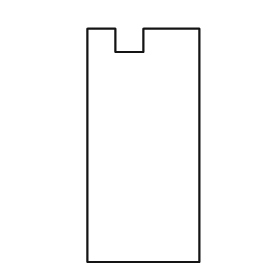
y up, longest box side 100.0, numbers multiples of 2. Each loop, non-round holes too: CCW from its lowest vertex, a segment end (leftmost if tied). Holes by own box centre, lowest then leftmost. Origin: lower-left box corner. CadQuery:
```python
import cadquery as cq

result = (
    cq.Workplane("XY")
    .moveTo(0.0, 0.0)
    .lineTo(48.0, 0.0)
    .lineTo(48.0, 100.0)
    .lineTo(24.0, 100.0)
    .lineTo(24.0, 90.0)
    .lineTo(12.0, 90.0)
    .lineTo(12.0, 100.0)
    .lineTo(0.0, 100.0)
    .close()
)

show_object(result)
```